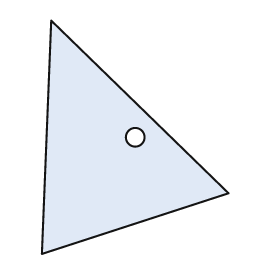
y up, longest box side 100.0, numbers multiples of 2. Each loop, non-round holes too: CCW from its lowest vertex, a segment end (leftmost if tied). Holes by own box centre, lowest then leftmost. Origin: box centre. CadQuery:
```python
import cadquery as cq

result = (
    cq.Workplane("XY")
    .moveTo(-40.0, -50.0)
    .lineTo(40.0, -24.0)
    .lineTo(-36.0, 50.0)
    .close()
    .moveTo(0.0, 0.0)
    .circle(4.0)
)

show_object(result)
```